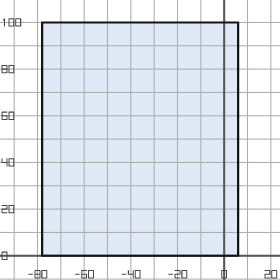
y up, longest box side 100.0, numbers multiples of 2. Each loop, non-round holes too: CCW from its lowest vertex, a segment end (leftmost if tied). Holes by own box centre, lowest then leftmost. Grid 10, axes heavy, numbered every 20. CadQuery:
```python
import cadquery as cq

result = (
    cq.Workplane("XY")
    .moveTo(-78.0, 0.0)
    .lineTo(6.0, 0.0)
    .lineTo(6.0, 100.0)
    .lineTo(-78.0, 100.0)
    .close()
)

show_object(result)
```